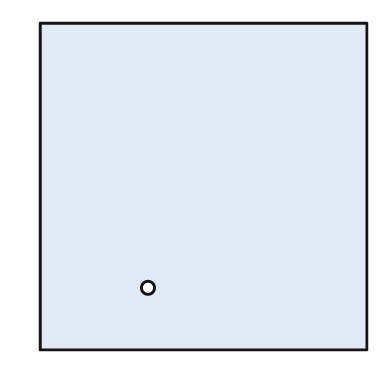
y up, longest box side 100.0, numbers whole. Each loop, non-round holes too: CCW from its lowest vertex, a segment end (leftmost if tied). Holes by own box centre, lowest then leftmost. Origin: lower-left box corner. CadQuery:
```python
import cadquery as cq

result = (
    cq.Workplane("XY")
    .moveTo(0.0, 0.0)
    .lineTo(100.0, 0.0)
    .lineTo(100.0, 100.0)
    .lineTo(0.0, 100.0)
    .close()
    .moveTo(33.0, 19.0)
    .circle(2.0)
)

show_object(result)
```